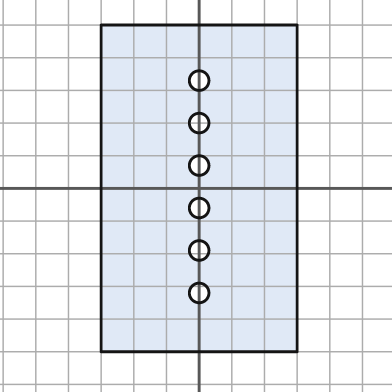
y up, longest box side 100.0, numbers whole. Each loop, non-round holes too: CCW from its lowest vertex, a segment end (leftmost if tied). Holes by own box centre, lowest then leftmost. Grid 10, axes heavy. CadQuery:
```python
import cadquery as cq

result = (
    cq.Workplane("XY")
    .moveTo(-30.0, -50.0)
    .lineTo(30.0, -50.0)
    .lineTo(30.0, 50.0)
    .lineTo(-30.0, 50.0)
    .close()
    .moveTo(0.0, -32.0)
    .circle(3.0)
    .moveTo(0.0, -19.0)
    .circle(3.0)
    .moveTo(0.0, -6.0)
    .circle(3.0)
    .moveTo(0.0, 7.0)
    .circle(3.0)
    .moveTo(0.0, 20.0)
    .circle(3.0)
    .moveTo(0.0, 33.0)
    .circle(3.0)
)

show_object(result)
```